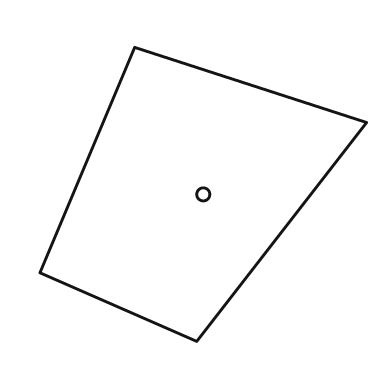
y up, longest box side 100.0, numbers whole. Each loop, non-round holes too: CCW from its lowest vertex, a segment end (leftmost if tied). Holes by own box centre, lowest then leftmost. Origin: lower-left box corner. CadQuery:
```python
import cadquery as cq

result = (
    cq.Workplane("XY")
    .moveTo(48.0, 0.0)
    .lineTo(100.0, 67.0)
    .lineTo(29.0, 90.0)
    .lineTo(0.0, 21.0)
    .close()
    .moveTo(50.0, 45.0)
    .circle(2.0)
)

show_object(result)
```